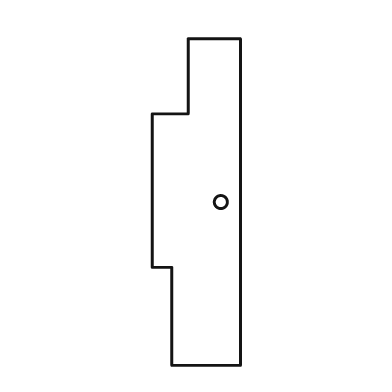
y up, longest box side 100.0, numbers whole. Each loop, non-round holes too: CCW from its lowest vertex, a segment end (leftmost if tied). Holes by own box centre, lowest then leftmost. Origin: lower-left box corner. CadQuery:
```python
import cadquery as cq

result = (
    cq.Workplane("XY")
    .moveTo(6.0, 0.0)
    .lineTo(27.0, 0.0)
    .lineTo(27.0, 100.0)
    .lineTo(11.0, 100.0)
    .lineTo(11.0, 77.0)
    .lineTo(0.0, 77.0)
    .lineTo(0.0, 30.0)
    .lineTo(6.0, 30.0)
    .close()
    .moveTo(21.0, 50.0)
    .circle(2.0)
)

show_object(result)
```